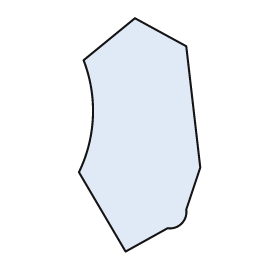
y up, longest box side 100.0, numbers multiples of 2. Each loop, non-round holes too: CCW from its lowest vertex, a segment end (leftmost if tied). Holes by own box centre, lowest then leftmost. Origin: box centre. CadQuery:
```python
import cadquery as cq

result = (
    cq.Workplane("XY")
    .moveTo(-6.0, -50.0)
    .lineTo(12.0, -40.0)
    .threePointArc((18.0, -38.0), (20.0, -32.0))
    .lineTo(26.0, -14.0)
    .lineTo(20.0, 38.0)
    .lineTo(-2.0, 50.0)
    .lineTo(-24.0, 32.0)
    .threePointArc((-20.0, 8.0), (-26.0, -16.0))
    .close()
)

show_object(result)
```